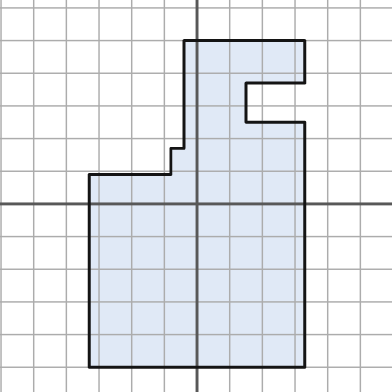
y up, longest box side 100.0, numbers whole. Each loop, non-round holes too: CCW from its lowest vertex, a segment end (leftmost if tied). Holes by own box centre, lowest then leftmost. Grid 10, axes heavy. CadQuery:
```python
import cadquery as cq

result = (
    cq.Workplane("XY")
    .moveTo(-33.0, -50.0)
    .lineTo(33.0, -50.0)
    .lineTo(33.0, 25.0)
    .lineTo(15.0, 25.0)
    .lineTo(15.0, 37.0)
    .lineTo(33.0, 37.0)
    .lineTo(33.0, 50.0)
    .lineTo(-4.0, 50.0)
    .lineTo(-4.0, 17.0)
    .lineTo(-8.0, 17.0)
    .lineTo(-8.0, 9.0)
    .lineTo(-33.0, 9.0)
    .close()
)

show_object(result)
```